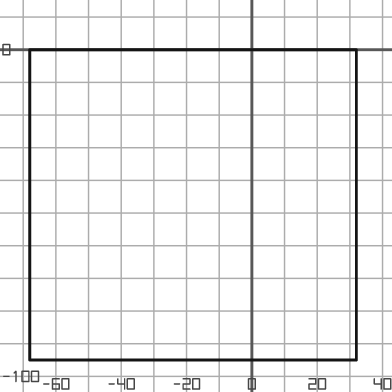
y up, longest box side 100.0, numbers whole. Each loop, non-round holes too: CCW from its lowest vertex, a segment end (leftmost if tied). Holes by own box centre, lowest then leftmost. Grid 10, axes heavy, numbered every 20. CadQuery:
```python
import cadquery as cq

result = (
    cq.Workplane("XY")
    .moveTo(-68.0, -95.0)
    .lineTo(32.0, -95.0)
    .lineTo(32.0, 0.0)
    .lineTo(-68.0, 0.0)
    .close()
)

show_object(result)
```